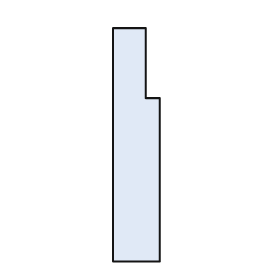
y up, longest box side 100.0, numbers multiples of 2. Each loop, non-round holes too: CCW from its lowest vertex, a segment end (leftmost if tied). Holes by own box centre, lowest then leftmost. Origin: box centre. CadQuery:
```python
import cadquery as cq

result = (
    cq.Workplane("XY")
    .moveTo(-10.0, -50.0)
    .lineTo(10.0, -50.0)
    .lineTo(10.0, 20.0)
    .lineTo(4.0, 20.0)
    .lineTo(4.0, 50.0)
    .lineTo(-10.0, 50.0)
    .close()
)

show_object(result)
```